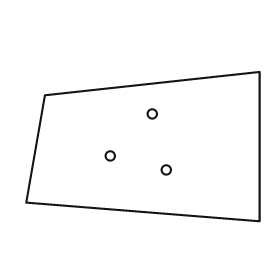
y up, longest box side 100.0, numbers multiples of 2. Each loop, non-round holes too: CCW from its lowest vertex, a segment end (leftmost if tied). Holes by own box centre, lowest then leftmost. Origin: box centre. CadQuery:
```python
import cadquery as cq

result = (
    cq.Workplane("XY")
    .moveTo(50.0, -32.0)
    .lineTo(50.0, 32.0)
    .lineTo(-42.0, 22.0)
    .lineTo(-50.0, -24.0)
    .close()
    .moveTo(10.0, -10.0)
    .circle(2.0)
    .moveTo(-14.0, -4.0)
    .circle(2.0)
    .moveTo(4.0, 14.0)
    .circle(2.0)
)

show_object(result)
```